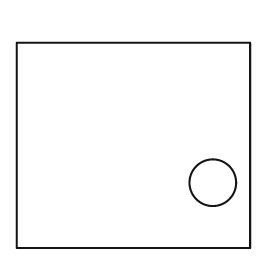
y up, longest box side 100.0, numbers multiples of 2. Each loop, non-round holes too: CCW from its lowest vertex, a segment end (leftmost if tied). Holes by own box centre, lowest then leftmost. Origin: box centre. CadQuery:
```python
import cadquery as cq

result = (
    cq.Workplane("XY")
    .moveTo(-50.0, -44.0)
    .lineTo(50.0, -44.0)
    .lineTo(50.0, 44.0)
    .lineTo(-50.0, 44.0)
    .close()
    .moveTo(34.0, -16.0)
    .circle(10.0)
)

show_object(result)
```